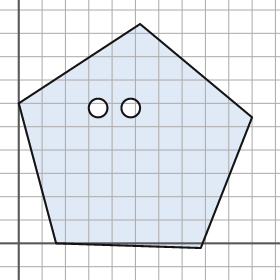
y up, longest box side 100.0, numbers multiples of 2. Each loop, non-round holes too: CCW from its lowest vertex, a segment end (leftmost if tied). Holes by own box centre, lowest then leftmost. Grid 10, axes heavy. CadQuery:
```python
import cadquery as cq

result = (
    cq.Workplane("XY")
    .moveTo(78.0, -2.0)
    .lineTo(100.0, 54.0)
    .lineTo(52.0, 94.0)
    .lineTo(0.0, 60.0)
    .lineTo(16.0, 0.0)
    .close()
    .moveTo(34.0, 58.0)
    .circle(4.0)
    .moveTo(48.0, 58.0)
    .circle(4.0)
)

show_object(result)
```